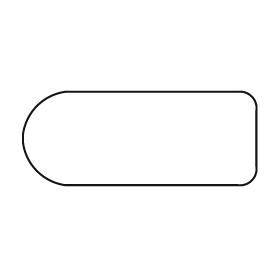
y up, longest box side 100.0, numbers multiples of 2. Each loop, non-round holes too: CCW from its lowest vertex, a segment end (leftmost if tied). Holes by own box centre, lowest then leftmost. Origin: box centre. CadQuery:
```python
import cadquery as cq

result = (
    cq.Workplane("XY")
    .moveTo(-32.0, -20.0)
    .lineTo(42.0, -20.0)
    .threePointArc((48.0, -18.0), (50.0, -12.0))
    .lineTo(50.0, 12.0)
    .threePointArc((48.0, 18.0), (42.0, 20.0))
    .lineTo(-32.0, 20.0)
    .threePointArc((-44.0, 14.0), (-50.0, 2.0))
    .lineTo(-50.0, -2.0)
    .threePointArc((-44.0, -14.0), (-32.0, -20.0))
    .close()
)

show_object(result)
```